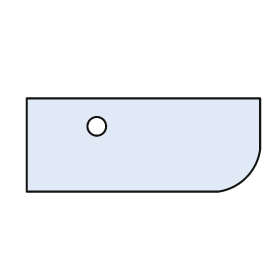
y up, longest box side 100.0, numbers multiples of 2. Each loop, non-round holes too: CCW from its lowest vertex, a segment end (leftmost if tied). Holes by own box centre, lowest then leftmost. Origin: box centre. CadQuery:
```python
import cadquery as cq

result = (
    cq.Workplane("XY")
    .moveTo(-50.0, -20.0)
    .lineTo(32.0, -20.0)
    .threePointArc((44.0, -14.0), (50.0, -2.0))
    .lineTo(50.0, 20.0)
    .lineTo(-50.0, 20.0)
    .close()
    .moveTo(-20.0, 8.0)
    .circle(4.0)
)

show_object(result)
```